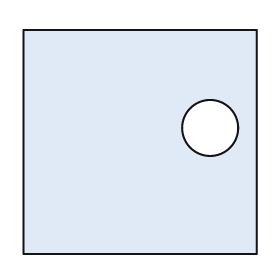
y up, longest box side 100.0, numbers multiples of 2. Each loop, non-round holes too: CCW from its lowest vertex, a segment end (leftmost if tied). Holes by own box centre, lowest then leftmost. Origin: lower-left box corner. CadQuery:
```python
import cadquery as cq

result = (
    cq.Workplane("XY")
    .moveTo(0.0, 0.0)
    .lineTo(100.0, 0.0)
    .lineTo(100.0, 96.0)
    .lineTo(0.0, 96.0)
    .close()
    .moveTo(80.0, 54.0)
    .circle(12.0)
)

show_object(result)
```